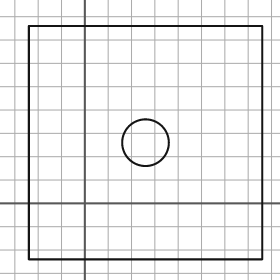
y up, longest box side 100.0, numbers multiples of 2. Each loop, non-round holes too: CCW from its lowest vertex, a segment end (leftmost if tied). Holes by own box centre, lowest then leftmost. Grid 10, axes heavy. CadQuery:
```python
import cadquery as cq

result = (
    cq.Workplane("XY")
    .moveTo(-24.0, -24.0)
    .lineTo(76.0, -24.0)
    .lineTo(76.0, 76.0)
    .lineTo(-24.0, 76.0)
    .close()
    .moveTo(26.0, 26.0)
    .circle(10.0)
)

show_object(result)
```